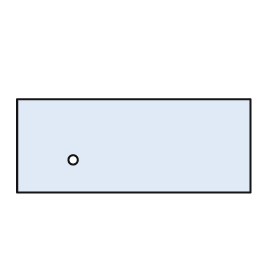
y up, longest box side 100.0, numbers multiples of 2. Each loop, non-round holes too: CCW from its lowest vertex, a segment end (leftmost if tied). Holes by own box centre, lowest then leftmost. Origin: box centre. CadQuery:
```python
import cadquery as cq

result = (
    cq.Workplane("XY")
    .moveTo(-50.0, -20.0)
    .lineTo(50.0, -20.0)
    .lineTo(50.0, 20.0)
    .lineTo(-50.0, 20.0)
    .close()
    .moveTo(-26.0, -6.0)
    .circle(2.0)
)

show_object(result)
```